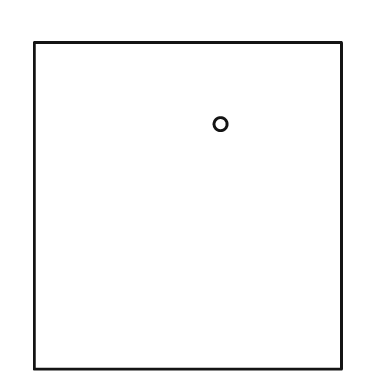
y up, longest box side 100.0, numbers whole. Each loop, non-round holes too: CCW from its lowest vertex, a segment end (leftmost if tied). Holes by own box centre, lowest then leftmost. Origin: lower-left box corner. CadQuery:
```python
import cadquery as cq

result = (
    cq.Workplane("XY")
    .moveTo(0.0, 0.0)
    .lineTo(94.0, 0.0)
    .lineTo(94.0, 100.0)
    .lineTo(0.0, 100.0)
    .close()
    .moveTo(57.0, 75.0)
    .circle(2.0)
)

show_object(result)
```